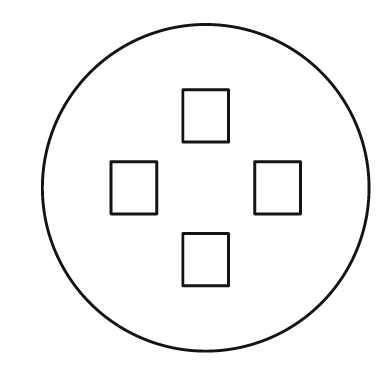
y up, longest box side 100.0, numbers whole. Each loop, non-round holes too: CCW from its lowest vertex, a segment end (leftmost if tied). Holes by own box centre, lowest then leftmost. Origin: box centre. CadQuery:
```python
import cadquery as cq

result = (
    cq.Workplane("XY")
    .moveTo(0.0, 0.0)
    .circle(50.0)
    .moveTo(-7.0, -30.0)
    .lineTo(7.0, -30.0)
    .lineTo(7.0, -14.0)
    .lineTo(-7.0, -14.0)
    .close()
    .moveTo(-29.0, -8.0)
    .lineTo(-15.0, -8.0)
    .lineTo(-15.0, 8.0)
    .lineTo(-29.0, 8.0)
    .close()
    .moveTo(15.0, -8.0)
    .lineTo(29.0, -8.0)
    .lineTo(29.0, 8.0)
    .lineTo(15.0, 8.0)
    .close()
    .moveTo(-7.0, 14.0)
    .lineTo(7.0, 14.0)
    .lineTo(7.0, 30.0)
    .lineTo(-7.0, 30.0)
    .close()
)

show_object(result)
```